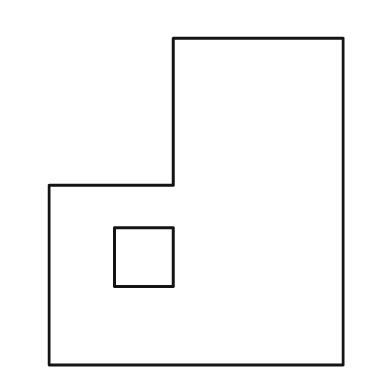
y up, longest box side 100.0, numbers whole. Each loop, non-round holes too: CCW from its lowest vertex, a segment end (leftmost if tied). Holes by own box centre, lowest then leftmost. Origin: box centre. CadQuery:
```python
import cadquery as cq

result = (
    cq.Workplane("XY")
    .moveTo(-45.0, -50.0)
    .lineTo(45.0, -50.0)
    .lineTo(45.0, 50.0)
    .lineTo(-7.0, 50.0)
    .lineTo(-7.0, 5.0)
    .lineTo(-45.0, 5.0)
    .close()
    .moveTo(-25.0, -26.0)
    .lineTo(-7.0, -26.0)
    .lineTo(-7.0, -8.0)
    .lineTo(-25.0, -8.0)
    .close()
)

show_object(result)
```